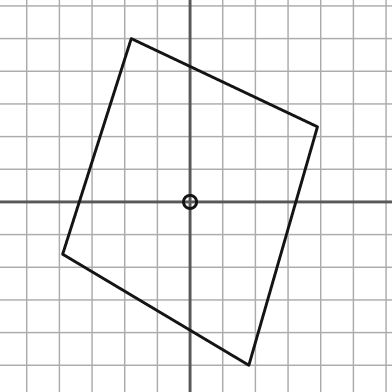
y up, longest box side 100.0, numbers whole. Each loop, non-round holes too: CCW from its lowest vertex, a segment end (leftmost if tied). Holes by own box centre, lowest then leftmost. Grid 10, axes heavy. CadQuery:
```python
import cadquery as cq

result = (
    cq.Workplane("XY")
    .moveTo(18.0, -50.0)
    .lineTo(39.0, 23.0)
    .lineTo(-18.0, 50.0)
    .lineTo(-39.0, -16.0)
    .close()
    .moveTo(0.0, 0.0)
    .circle(2.0)
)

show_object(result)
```